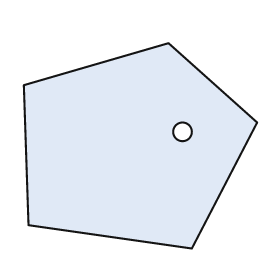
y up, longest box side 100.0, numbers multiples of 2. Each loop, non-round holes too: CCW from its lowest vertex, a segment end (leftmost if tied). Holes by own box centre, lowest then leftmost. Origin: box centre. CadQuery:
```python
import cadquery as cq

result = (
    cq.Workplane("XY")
    .moveTo(22.0, -44.0)
    .lineTo(50.0, 10.0)
    .lineTo(12.0, 44.0)
    .lineTo(-50.0, 26.0)
    .lineTo(-48.0, -34.0)
    .close()
    .moveTo(18.0, 6.0)
    .circle(4.0)
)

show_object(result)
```